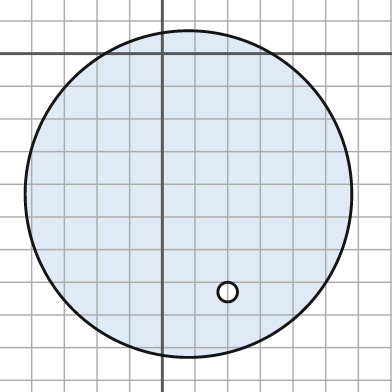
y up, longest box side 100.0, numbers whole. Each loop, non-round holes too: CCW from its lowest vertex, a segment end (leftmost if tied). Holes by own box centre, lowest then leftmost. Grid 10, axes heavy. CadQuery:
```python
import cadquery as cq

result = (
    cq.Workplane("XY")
    .moveTo(8.0, -43.0)
    .circle(50.0)
    .moveTo(20.0, -73.0)
    .circle(3.0)
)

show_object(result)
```